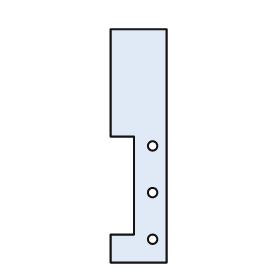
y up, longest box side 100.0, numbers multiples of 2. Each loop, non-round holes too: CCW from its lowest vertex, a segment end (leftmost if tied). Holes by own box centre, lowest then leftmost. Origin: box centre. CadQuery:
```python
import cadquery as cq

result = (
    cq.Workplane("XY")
    .moveTo(-12.0, -50.0)
    .lineTo(12.0, -50.0)
    .lineTo(12.0, 50.0)
    .lineTo(-12.0, 50.0)
    .lineTo(-12.0, 4.0)
    .lineTo(-2.0, 4.0)
    .lineTo(-2.0, -38.0)
    .lineTo(-12.0, -38.0)
    .close()
    .moveTo(6.0, -40.0)
    .circle(2.0)
    .moveTo(6.0, -20.0)
    .circle(2.0)
    .moveTo(6.0, 0.0)
    .circle(2.0)
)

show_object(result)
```